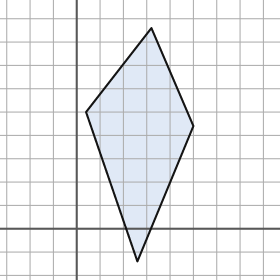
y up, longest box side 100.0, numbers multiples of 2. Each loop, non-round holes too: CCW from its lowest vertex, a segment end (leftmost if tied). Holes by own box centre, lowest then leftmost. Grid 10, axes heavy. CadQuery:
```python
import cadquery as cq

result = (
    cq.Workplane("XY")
    .moveTo(26.0, -14.0)
    .lineTo(50.0, 44.0)
    .lineTo(32.0, 86.0)
    .lineTo(4.0, 50.0)
    .close()
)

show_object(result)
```